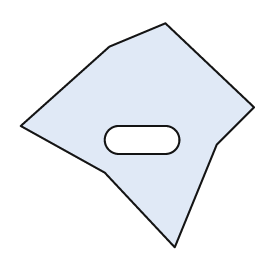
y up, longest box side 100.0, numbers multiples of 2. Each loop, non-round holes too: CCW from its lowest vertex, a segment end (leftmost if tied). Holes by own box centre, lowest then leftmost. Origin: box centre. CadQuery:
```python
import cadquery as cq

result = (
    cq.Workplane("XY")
    .moveTo(16.0, -48.0)
    .lineTo(34.0, -4.0)
    .lineTo(50.0, 12.0)
    .lineTo(12.0, 48.0)
    .lineTo(-12.0, 38.0)
    .lineTo(-50.0, 4.0)
    .lineTo(-14.0, -16.0)
    .close()
    .moveTo(-8.0, -8.0)
    .lineTo(12.0, -8.0)
    .threePointArc((18.0, -2.0), (12.0, 4.0))
    .lineTo(-8.0, 4.0)
    .threePointArc((-14.0, -2.0), (-8.0, -8.0))
    .close()
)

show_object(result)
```